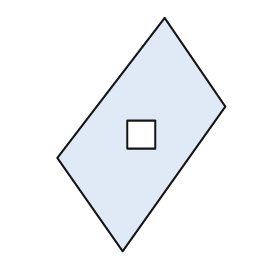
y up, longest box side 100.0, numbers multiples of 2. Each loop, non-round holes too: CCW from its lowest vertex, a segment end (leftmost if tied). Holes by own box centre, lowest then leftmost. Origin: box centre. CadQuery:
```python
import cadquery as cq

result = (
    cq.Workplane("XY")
    .moveTo(-8.0, -50.0)
    .lineTo(36.0, 12.0)
    .lineTo(10.0, 50.0)
    .lineTo(-36.0, -10.0)
    .close()
    .moveTo(-6.0, -6.0)
    .lineTo(6.0, -6.0)
    .lineTo(6.0, 6.0)
    .lineTo(-6.0, 6.0)
    .close()
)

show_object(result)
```